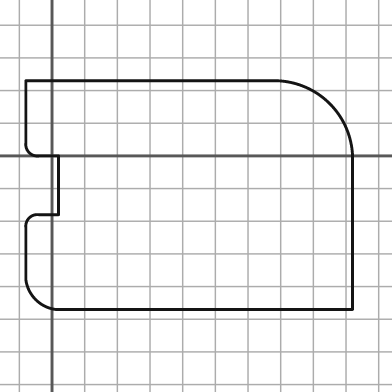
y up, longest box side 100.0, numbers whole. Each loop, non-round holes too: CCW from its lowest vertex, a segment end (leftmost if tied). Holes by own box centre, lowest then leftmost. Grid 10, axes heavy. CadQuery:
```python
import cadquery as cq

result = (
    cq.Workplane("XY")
    .moveTo(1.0, -47.0)
    .lineTo(92.0, -47.0)
    .lineTo(92.0, 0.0)
    .threePointArc((85.0, 16.0), (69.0, 23.0))
    .lineTo(-8.0, 23.0)
    .lineTo(-8.0, 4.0)
    .threePointArc((-7.0, 1.0), (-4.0, 0.0))
    .lineTo(2.0, 0.0)
    .lineTo(2.0, -18.0)
    .lineTo(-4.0, -18.0)
    .threePointArc((-7.0, -19.0), (-8.0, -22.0))
    .lineTo(-8.0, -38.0)
    .threePointArc((-5.0, -44.0), (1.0, -47.0))
    .close()
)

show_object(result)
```